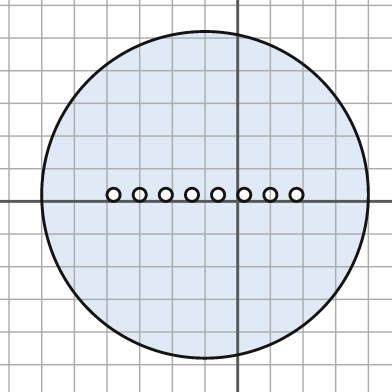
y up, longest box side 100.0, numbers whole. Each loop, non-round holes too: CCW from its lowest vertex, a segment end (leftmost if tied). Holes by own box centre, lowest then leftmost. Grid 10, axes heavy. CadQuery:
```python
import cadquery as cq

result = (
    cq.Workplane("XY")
    .moveTo(-10.0, 2.0)
    .circle(50.0)
    .moveTo(-38.0, 2.0)
    .circle(2.0)
    .moveTo(-30.0, 2.0)
    .circle(2.0)
    .moveTo(-22.0, 2.0)
    .circle(2.0)
    .moveTo(-14.0, 2.0)
    .circle(2.0)
    .moveTo(-6.0, 2.0)
    .circle(2.0)
    .moveTo(2.0, 2.0)
    .circle(2.0)
    .moveTo(10.0, 2.0)
    .circle(2.0)
    .moveTo(18.0, 2.0)
    .circle(2.0)
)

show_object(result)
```